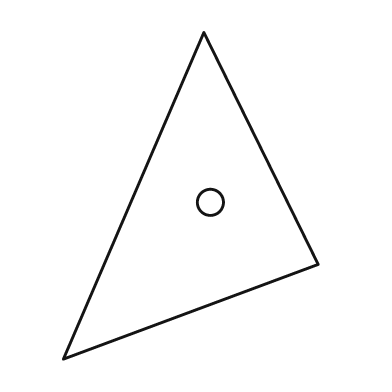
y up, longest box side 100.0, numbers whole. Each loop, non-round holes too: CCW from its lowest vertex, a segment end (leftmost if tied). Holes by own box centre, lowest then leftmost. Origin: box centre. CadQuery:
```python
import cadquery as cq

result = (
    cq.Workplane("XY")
    .moveTo(-39.0, -50.0)
    .lineTo(39.0, -21.0)
    .lineTo(4.0, 50.0)
    .close()
    .moveTo(6.0, -2.0)
    .circle(4.0)
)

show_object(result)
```